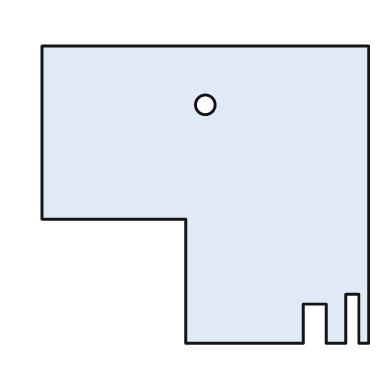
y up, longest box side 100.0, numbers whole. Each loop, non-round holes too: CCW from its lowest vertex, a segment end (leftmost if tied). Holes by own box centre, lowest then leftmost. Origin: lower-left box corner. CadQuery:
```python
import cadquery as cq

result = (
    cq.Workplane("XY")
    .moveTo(44.0, 0.0)
    .lineTo(80.0, 0.0)
    .lineTo(80.0, 12.0)
    .lineTo(87.0, 12.0)
    .lineTo(87.0, 0.0)
    .lineTo(93.0, 0.0)
    .lineTo(93.0, 15.0)
    .lineTo(97.0, 15.0)
    .lineTo(97.0, 0.0)
    .lineTo(100.0, 0.0)
    .lineTo(100.0, 91.0)
    .lineTo(0.0, 91.0)
    .lineTo(0.0, 38.0)
    .lineTo(44.0, 38.0)
    .close()
    .moveTo(50.0, 73.0)
    .circle(3.0)
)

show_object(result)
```